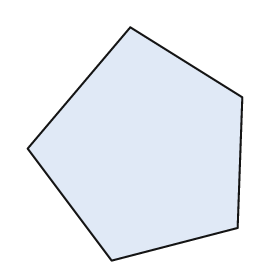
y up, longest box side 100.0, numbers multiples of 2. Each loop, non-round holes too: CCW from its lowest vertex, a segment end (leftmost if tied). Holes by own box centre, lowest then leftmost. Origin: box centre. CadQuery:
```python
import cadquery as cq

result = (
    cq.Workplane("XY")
    .moveTo(-10.0, -50.0)
    .lineTo(44.0, -36.0)
    .lineTo(46.0, 20.0)
    .lineTo(-2.0, 50.0)
    .lineTo(-46.0, -2.0)
    .close()
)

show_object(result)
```